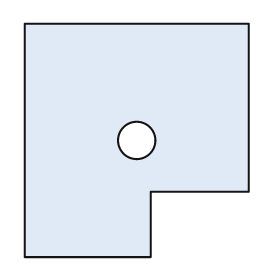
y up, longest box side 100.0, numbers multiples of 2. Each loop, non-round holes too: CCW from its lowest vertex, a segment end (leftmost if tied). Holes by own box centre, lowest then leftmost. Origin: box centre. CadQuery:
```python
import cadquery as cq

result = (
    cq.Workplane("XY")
    .moveTo(-48.0, -50.0)
    .lineTo(6.0, -50.0)
    .lineTo(6.0, -22.0)
    .lineTo(48.0, -22.0)
    .lineTo(48.0, 50.0)
    .lineTo(-48.0, 50.0)
    .close()
    .moveTo(0.0, 0.0)
    .circle(8.0)
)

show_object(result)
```